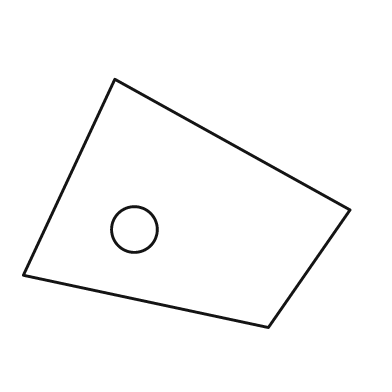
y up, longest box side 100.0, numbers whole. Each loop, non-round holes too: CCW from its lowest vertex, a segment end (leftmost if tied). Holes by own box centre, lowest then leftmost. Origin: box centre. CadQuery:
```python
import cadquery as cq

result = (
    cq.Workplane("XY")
    .moveTo(25.0, -38.0)
    .lineTo(50.0, -2.0)
    .lineTo(-22.0, 38.0)
    .lineTo(-50.0, -22.0)
    .close()
    .moveTo(-16.0, -8.0)
    .circle(7.0)
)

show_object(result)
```